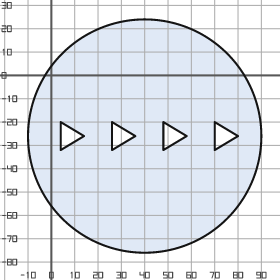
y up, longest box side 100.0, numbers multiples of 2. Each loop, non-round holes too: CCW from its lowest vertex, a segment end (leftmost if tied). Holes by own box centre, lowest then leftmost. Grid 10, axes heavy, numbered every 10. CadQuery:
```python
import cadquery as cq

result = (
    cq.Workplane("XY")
    .moveTo(40.0, -26.0)
    .circle(50.0)
    .moveTo(4.0, -32.0)
    .lineTo(14.0, -26.0)
    .lineTo(4.0, -20.0)
    .close()
    .moveTo(26.0, -32.0)
    .lineTo(36.0, -26.0)
    .lineTo(26.0, -20.0)
    .close()
    .moveTo(48.0, -32.0)
    .lineTo(58.0, -26.0)
    .lineTo(48.0, -20.0)
    .close()
    .moveTo(70.0, -32.0)
    .lineTo(80.0, -26.0)
    .lineTo(70.0, -20.0)
    .close()
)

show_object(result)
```